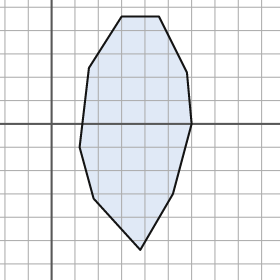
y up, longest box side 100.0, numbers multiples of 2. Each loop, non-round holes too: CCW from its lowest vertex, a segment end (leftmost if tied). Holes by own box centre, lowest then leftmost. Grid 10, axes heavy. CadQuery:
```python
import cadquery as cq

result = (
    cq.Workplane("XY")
    .moveTo(38.0, -54.0)
    .lineTo(52.0, -30.0)
    .lineTo(60.0, 0.0)
    .lineTo(58.0, 22.0)
    .lineTo(46.0, 46.0)
    .lineTo(30.0, 46.0)
    .lineTo(16.0, 24.0)
    .lineTo(12.0, -10.0)
    .lineTo(18.0, -32.0)
    .close()
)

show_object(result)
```